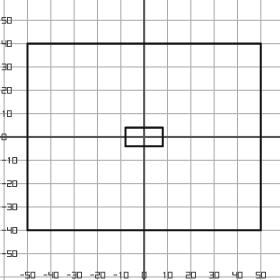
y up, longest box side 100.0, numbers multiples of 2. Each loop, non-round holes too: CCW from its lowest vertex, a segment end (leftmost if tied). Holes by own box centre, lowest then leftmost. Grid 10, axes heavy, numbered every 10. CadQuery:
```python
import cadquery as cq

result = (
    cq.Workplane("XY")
    .moveTo(-50.0, -40.0)
    .lineTo(50.0, -40.0)
    .lineTo(50.0, 40.0)
    .lineTo(-50.0, 40.0)
    .close()
    .moveTo(-8.0, -4.0)
    .lineTo(8.0, -4.0)
    .lineTo(8.0, 4.0)
    .lineTo(-8.0, 4.0)
    .close()
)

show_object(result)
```